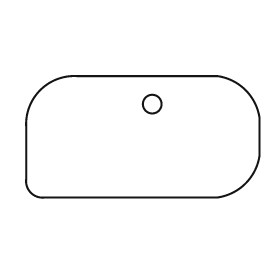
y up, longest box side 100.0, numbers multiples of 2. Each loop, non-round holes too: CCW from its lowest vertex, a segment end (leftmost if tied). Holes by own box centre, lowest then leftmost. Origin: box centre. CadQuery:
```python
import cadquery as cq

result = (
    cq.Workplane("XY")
    .moveTo(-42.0, -26.0)
    .lineTo(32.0, -26.0)
    .threePointArc((44.0, -20.0), (50.0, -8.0))
    .lineTo(50.0, 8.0)
    .threePointArc((44.0, 20.0), (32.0, 26.0))
    .lineTo(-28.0, 26.0)
    .threePointArc((-44.0, 20.0), (-50.0, 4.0))
    .lineTo(-50.0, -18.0)
    .threePointArc((-48.0, -24.0), (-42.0, -26.0))
    .close()
    .moveTo(4.0, 14.0)
    .circle(4.0)
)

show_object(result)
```